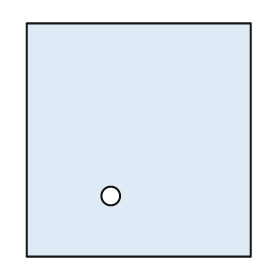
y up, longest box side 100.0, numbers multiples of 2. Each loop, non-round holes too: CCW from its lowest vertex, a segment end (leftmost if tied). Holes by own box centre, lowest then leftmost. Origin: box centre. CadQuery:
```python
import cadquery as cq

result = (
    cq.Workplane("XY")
    .moveTo(-48.0, -50.0)
    .lineTo(48.0, -50.0)
    .lineTo(48.0, 50.0)
    .lineTo(-48.0, 50.0)
    .close()
    .moveTo(-12.0, -24.0)
    .circle(4.0)
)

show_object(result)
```